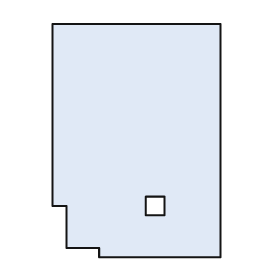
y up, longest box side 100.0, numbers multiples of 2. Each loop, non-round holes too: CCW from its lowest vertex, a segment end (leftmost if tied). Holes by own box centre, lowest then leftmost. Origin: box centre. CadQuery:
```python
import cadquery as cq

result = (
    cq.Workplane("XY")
    .moveTo(-16.0, -50.0)
    .lineTo(36.0, -50.0)
    .lineTo(36.0, 50.0)
    .lineTo(-36.0, 50.0)
    .lineTo(-36.0, -28.0)
    .lineTo(-30.0, -28.0)
    .lineTo(-30.0, -46.0)
    .lineTo(-16.0, -46.0)
    .close()
    .moveTo(4.0, -32.0)
    .lineTo(12.0, -32.0)
    .lineTo(12.0, -24.0)
    .lineTo(4.0, -24.0)
    .close()
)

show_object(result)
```